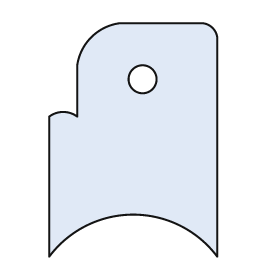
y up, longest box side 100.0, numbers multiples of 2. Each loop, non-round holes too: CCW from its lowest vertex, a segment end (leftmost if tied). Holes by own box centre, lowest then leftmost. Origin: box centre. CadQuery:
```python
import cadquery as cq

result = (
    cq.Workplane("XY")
    .moveTo(-36.0, -50.0)
    .threePointArc((0.0, -32.0), (36.0, -50.0))
    .lineTo(36.0, 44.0)
    .threePointArc((34.0, 48.0), (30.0, 50.0))
    .lineTo(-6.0, 50.0)
    .threePointArc((-18.0, 44.0), (-24.0, 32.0))
    .lineTo(-24.0, 10.0)
    .threePointArc((-30.0, 12.0), (-36.0, 10.0))
    .close()
    .moveTo(4.0, 26.0)
    .circle(6.0)
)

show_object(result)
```